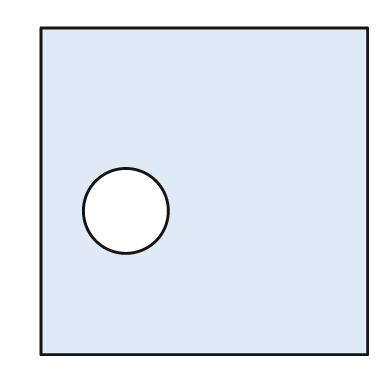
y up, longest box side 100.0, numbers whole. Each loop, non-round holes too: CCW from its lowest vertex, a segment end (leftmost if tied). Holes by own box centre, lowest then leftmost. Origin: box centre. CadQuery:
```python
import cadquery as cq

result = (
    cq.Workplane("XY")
    .moveTo(-50.0, -50.0)
    .lineTo(50.0, -50.0)
    .lineTo(50.0, 50.0)
    .lineTo(-50.0, 50.0)
    .close()
    .moveTo(-24.0, -6.0)
    .circle(13.0)
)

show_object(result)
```